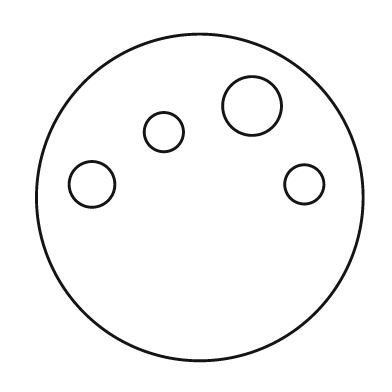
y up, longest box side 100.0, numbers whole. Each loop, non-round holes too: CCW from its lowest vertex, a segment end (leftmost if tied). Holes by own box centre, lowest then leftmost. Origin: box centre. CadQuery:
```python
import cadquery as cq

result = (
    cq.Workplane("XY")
    .moveTo(0.0, 0.0)
    .circle(50.0)
    .moveTo(-33.0, 4.0)
    .circle(7.0)
    .moveTo(32.0, 4.0)
    .circle(6.0)
    .moveTo(-11.0, 20.0)
    .circle(6.0)
    .moveTo(16.0, 28.0)
    .circle(9.0)
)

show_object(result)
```